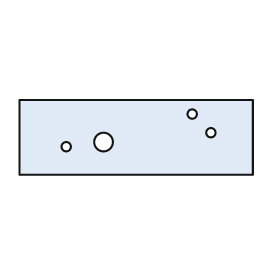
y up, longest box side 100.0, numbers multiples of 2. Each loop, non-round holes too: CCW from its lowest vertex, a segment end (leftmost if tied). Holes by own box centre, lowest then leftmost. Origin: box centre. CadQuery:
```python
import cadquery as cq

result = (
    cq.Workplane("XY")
    .moveTo(-50.0, -16.0)
    .lineTo(50.0, -16.0)
    .lineTo(50.0, 16.0)
    .lineTo(-50.0, 16.0)
    .close()
    .moveTo(-30.0, -4.0)
    .circle(2.0)
    .moveTo(-14.0, -2.0)
    .circle(4.0)
    .moveTo(32.0, 2.0)
    .circle(2.0)
    .moveTo(24.0, 10.0)
    .circle(2.0)
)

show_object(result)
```